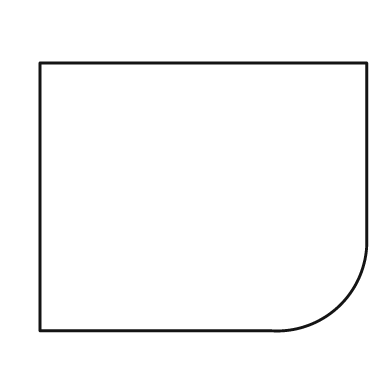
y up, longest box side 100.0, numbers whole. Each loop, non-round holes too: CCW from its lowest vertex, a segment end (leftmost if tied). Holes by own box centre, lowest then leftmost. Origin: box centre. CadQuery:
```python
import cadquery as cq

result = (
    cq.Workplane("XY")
    .moveTo(-50.0, -41.0)
    .lineTo(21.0, -41.0)
    .threePointArc((42.0, -33.0), (50.0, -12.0))
    .lineTo(50.0, 41.0)
    .lineTo(-50.0, 41.0)
    .close()
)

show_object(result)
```